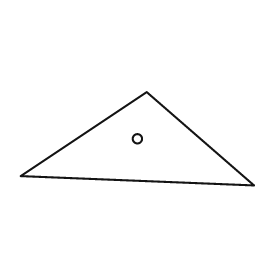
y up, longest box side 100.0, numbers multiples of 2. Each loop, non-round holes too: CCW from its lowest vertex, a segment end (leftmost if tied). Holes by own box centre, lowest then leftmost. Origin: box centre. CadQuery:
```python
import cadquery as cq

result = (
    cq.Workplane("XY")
    .moveTo(50.0, -20.0)
    .lineTo(4.0, 20.0)
    .lineTo(-50.0, -16.0)
    .close()
    .moveTo(0.0, 0.0)
    .circle(2.0)
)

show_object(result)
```